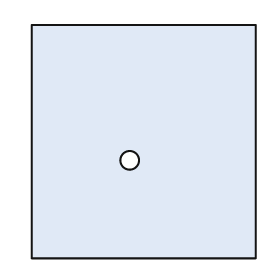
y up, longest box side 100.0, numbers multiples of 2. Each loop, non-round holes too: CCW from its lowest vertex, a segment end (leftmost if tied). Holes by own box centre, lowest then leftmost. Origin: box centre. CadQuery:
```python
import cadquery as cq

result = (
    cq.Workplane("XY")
    .moveTo(-48.0, -50.0)
    .lineTo(48.0, -50.0)
    .lineTo(48.0, 50.0)
    .lineTo(-48.0, 50.0)
    .close()
    .moveTo(-6.0, -8.0)
    .circle(4.0)
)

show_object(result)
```